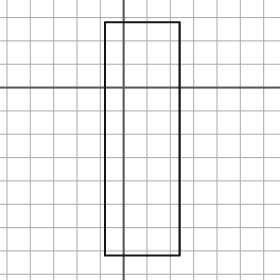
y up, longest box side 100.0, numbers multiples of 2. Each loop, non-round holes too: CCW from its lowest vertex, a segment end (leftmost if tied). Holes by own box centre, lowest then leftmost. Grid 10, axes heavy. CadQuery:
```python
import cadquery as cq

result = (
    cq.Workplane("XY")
    .moveTo(-8.0, -72.0)
    .lineTo(24.0, -72.0)
    .lineTo(24.0, 28.0)
    .lineTo(-8.0, 28.0)
    .close()
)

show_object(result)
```